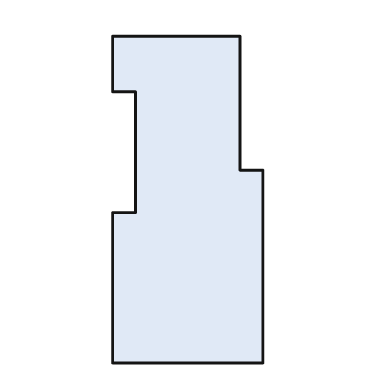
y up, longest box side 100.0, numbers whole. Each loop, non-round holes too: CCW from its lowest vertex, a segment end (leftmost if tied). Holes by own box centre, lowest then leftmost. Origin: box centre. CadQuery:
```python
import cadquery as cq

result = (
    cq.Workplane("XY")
    .moveTo(-23.0, -50.0)
    .lineTo(23.0, -50.0)
    .lineTo(23.0, 9.0)
    .lineTo(16.0, 9.0)
    .lineTo(16.0, 50.0)
    .lineTo(-23.0, 50.0)
    .lineTo(-23.0, 33.0)
    .lineTo(-16.0, 33.0)
    .lineTo(-16.0, -4.0)
    .lineTo(-23.0, -4.0)
    .close()
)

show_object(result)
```